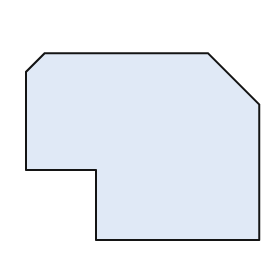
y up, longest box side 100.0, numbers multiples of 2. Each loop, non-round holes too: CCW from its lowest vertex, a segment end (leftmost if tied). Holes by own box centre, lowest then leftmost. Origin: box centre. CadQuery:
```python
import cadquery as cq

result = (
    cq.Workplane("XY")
    .moveTo(-20.0, -40.0)
    .lineTo(50.0, -40.0)
    .lineTo(50.0, 18.0)
    .lineTo(28.0, 40.0)
    .lineTo(-42.0, 40.0)
    .lineTo(-50.0, 32.0)
    .lineTo(-50.0, -10.0)
    .lineTo(-20.0, -10.0)
    .close()
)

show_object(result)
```